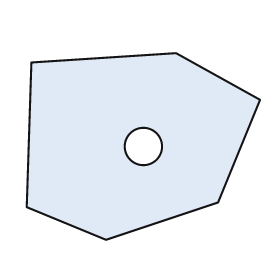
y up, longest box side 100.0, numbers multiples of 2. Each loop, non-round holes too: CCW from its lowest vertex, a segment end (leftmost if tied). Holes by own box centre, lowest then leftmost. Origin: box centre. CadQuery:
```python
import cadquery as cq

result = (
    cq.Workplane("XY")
    .moveTo(-16.0, -40.0)
    .lineTo(32.0, -24.0)
    .lineTo(50.0, 20.0)
    .lineTo(14.0, 40.0)
    .lineTo(-48.0, 36.0)
    .lineTo(-50.0, -26.0)
    .close()
    .moveTo(0.0, 0.0)
    .circle(8.0)
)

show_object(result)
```